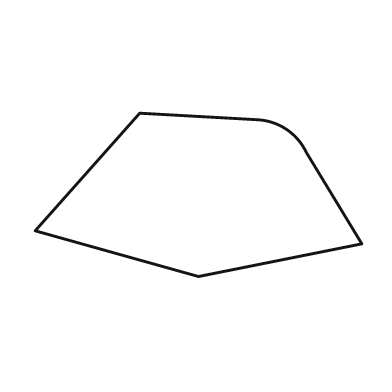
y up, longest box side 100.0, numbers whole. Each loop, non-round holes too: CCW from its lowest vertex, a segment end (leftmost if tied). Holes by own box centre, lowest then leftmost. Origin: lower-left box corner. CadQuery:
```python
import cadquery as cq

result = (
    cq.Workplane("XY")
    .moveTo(50.0, 0.0)
    .lineTo(100.0, 10.0)
    .lineTo(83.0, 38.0)
    .threePointArc((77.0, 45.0), (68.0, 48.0))
    .lineTo(32.0, 50.0)
    .lineTo(0.0, 14.0)
    .close()
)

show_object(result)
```